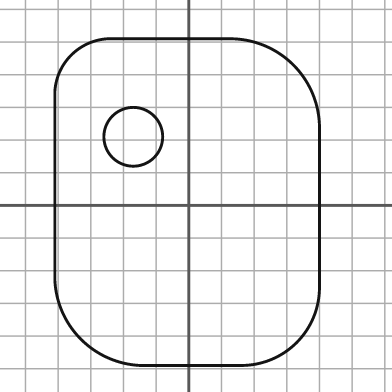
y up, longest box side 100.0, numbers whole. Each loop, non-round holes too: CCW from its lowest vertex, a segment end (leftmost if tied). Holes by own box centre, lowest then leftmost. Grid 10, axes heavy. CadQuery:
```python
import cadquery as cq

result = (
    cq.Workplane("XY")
    .moveTo(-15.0, -49.0)
    .lineTo(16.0, -49.0)
    .threePointArc((33.0, -42.0), (40.0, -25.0))
    .lineTo(40.0, 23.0)
    .threePointArc((32.0, 43.0), (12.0, 51.0))
    .lineTo(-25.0, 51.0)
    .threePointArc((-36.0, 46.0), (-41.0, 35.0))
    .lineTo(-41.0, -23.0)
    .threePointArc((-33.0, -41.0), (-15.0, -49.0))
    .close()
    .moveTo(-17.0, 21.0)
    .circle(9.0)
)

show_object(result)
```